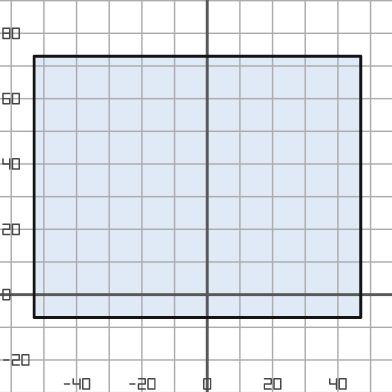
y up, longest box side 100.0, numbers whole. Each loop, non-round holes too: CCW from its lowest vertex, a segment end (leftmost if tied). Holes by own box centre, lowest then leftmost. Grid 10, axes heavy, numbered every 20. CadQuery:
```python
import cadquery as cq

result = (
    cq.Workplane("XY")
    .moveTo(-53.0, -7.0)
    .lineTo(47.0, -7.0)
    .lineTo(47.0, 73.0)
    .lineTo(-53.0, 73.0)
    .close()
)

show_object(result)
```